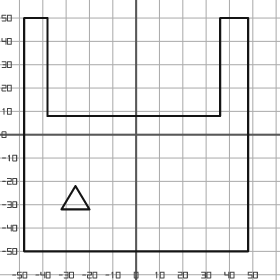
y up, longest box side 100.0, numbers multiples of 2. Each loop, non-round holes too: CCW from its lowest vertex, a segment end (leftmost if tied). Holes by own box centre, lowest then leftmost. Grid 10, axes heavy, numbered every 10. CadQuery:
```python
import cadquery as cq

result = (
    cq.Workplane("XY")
    .moveTo(-48.0, -50.0)
    .lineTo(48.0, -50.0)
    .lineTo(48.0, 50.0)
    .lineTo(36.0, 50.0)
    .lineTo(36.0, 8.0)
    .lineTo(-38.0, 8.0)
    .lineTo(-38.0, 50.0)
    .lineTo(-48.0, 50.0)
    .close()
    .moveTo(-32.0, -32.0)
    .lineTo(-20.0, -32.0)
    .lineTo(-26.0, -22.0)
    .close()
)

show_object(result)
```